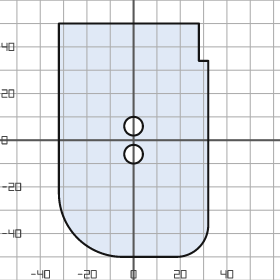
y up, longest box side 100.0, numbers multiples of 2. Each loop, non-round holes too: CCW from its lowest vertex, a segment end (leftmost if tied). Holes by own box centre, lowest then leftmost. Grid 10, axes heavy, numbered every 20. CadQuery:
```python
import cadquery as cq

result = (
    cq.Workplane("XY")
    .moveTo(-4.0, -50.0)
    .lineTo(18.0, -50.0)
    .threePointArc((28.0, -46.0), (32.0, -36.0))
    .lineTo(32.0, 34.0)
    .lineTo(28.0, 34.0)
    .lineTo(28.0, 50.0)
    .lineTo(-32.0, 50.0)
    .lineTo(-32.0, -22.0)
    .threePointArc((-24.0, -42.0), (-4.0, -50.0))
    .close()
    .moveTo(0.0, -6.0)
    .circle(4.0)
    .moveTo(0.0, 6.0)
    .circle(4.0)
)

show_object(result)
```